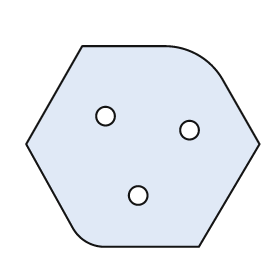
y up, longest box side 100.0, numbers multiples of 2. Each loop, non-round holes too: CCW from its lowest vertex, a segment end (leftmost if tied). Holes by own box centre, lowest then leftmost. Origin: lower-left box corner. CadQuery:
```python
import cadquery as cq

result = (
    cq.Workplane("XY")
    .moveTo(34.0, 0.0)
    .lineTo(74.0, 0.0)
    .lineTo(100.0, 44.0)
    .lineTo(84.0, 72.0)
    .threePointArc((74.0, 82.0), (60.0, 86.0))
    .lineTo(24.0, 86.0)
    .lineTo(0.0, 44.0)
    .lineTo(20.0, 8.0)
    .threePointArc((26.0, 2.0), (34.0, 0.0))
    .close()
    .moveTo(48.0, 22.0)
    .circle(4.0)
    .moveTo(70.0, 50.0)
    .circle(4.0)
    .moveTo(34.0, 56.0)
    .circle(4.0)
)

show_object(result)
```